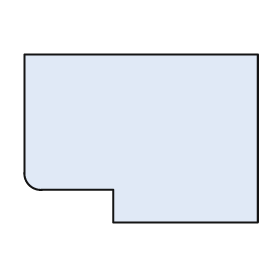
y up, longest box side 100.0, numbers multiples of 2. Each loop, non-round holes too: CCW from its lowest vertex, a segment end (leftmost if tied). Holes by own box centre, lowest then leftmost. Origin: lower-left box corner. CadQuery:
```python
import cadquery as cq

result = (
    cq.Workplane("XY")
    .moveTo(38.0, 0.0)
    .lineTo(100.0, 0.0)
    .lineTo(100.0, 72.0)
    .lineTo(0.0, 72.0)
    .lineTo(0.0, 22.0)
    .threePointArc((2.0, 16.0), (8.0, 14.0))
    .lineTo(38.0, 14.0)
    .close()
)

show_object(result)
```